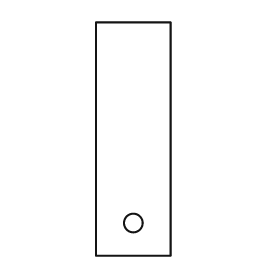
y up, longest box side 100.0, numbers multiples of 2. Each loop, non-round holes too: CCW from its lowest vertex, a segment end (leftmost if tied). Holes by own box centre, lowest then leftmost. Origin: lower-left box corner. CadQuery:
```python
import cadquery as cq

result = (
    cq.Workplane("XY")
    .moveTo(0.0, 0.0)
    .lineTo(32.0, 0.0)
    .lineTo(32.0, 100.0)
    .lineTo(0.0, 100.0)
    .close()
    .moveTo(16.0, 14.0)
    .circle(4.0)
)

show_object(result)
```